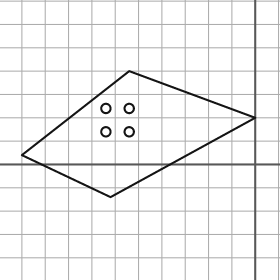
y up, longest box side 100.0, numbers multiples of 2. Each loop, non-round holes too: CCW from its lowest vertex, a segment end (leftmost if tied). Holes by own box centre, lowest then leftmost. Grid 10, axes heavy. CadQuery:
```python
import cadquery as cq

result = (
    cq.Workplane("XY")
    .moveTo(-62.0, -14.0)
    .lineTo(0.0, 20.0)
    .lineTo(-54.0, 40.0)
    .lineTo(-100.0, 4.0)
    .close()
    .moveTo(-64.0, 14.0)
    .circle(2.0)
    .moveTo(-54.0, 14.0)
    .circle(2.0)
    .moveTo(-64.0, 24.0)
    .circle(2.0)
    .moveTo(-54.0, 24.0)
    .circle(2.0)
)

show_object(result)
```